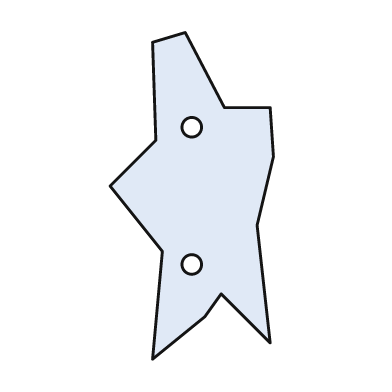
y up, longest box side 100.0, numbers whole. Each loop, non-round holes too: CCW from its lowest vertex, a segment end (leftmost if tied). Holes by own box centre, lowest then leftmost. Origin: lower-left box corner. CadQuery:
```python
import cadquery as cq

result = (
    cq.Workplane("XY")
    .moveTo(13.0, 0.0)
    .lineTo(29.0, 13.0)
    .lineTo(34.0, 20.0)
    .lineTo(49.0, 5.0)
    .lineTo(45.0, 41.0)
    .lineTo(50.0, 62.0)
    .lineTo(49.0, 77.0)
    .lineTo(35.0, 77.0)
    .lineTo(23.0, 100.0)
    .lineTo(13.0, 97.0)
    .lineTo(14.0, 67.0)
    .lineTo(0.0, 53.0)
    .lineTo(16.0, 33.0)
    .close()
    .moveTo(25.0, 29.0)
    .circle(3.0)
    .moveTo(25.0, 71.0)
    .circle(3.0)
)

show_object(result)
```